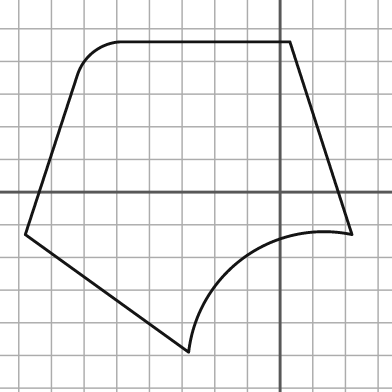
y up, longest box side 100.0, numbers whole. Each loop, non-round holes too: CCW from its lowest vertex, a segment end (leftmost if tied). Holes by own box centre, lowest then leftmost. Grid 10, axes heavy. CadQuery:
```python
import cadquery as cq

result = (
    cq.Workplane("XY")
    .moveTo(-28.0, -49.0)
    .threePointArc((-11.0, -20.0), (22.0, -13.0))
    .lineTo(3.0, 46.0)
    .lineTo(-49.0, 46.0)
    .threePointArc((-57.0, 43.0), (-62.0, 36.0))
    .lineTo(-78.0, -13.0)
    .close()
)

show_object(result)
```